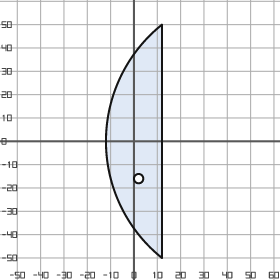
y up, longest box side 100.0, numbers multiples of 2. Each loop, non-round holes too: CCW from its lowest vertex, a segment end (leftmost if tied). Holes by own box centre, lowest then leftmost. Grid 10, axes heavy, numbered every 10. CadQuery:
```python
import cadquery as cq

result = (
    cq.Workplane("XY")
    .moveTo(12.0, -50.0)
    .lineTo(12.0, 50.0)
    .threePointArc((-12.0, 0.0), (12.0, -50.0))
    .close()
    .moveTo(2.0, -16.0)
    .circle(2.0)
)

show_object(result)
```